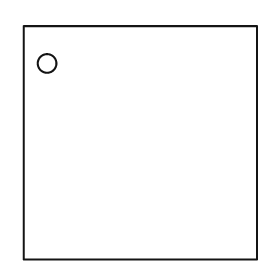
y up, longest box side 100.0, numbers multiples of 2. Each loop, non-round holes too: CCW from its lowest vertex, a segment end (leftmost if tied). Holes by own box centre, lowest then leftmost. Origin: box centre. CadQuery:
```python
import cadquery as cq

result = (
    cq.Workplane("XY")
    .moveTo(-50.0, -50.0)
    .lineTo(50.0, -50.0)
    .lineTo(50.0, 50.0)
    .lineTo(-50.0, 50.0)
    .close()
    .moveTo(-40.0, 34.0)
    .circle(4.0)
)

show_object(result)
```